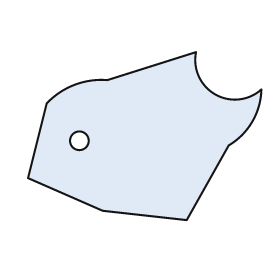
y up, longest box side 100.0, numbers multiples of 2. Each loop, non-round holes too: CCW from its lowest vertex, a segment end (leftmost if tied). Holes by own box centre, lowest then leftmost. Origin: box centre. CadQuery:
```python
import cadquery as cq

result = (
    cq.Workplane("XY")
    .moveTo(18.0, -36.0)
    .lineTo(36.0, -4.0)
    .threePointArc((46.0, 6.0), (50.0, 20.0))
    .threePointArc((30.0, 18.0), (22.0, 36.0))
    .lineTo(-16.0, 24.0)
    .threePointArc((-30.0, 22.0), (-42.0, 14.0))
    .lineTo(-50.0, -18.0)
    .lineTo(-18.0, -32.0)
    .close()
    .moveTo(-28.0, -2.0)
    .circle(4.0)
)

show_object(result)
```